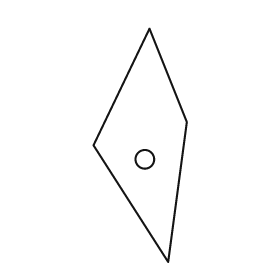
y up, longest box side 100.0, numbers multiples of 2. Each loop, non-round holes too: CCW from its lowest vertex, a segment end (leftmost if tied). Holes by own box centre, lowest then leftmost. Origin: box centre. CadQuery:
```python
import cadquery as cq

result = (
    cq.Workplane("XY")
    .moveTo(12.0, -50.0)
    .lineTo(20.0, 10.0)
    .lineTo(4.0, 50.0)
    .lineTo(-20.0, 0.0)
    .close()
    .moveTo(2.0, -6.0)
    .circle(4.0)
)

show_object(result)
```